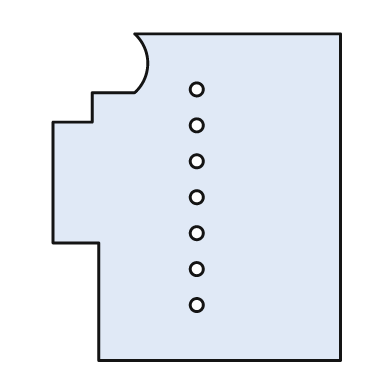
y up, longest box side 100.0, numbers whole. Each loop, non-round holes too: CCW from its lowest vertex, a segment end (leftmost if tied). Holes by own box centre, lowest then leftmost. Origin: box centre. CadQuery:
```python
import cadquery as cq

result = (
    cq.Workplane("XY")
    .moveTo(-30.0, -50.0)
    .lineTo(44.0, -50.0)
    .lineTo(44.0, 50.0)
    .lineTo(-19.0, 50.0)
    .threePointArc((-15.0, 41.0), (-19.0, 32.0))
    .lineTo(-32.0, 32.0)
    .lineTo(-32.0, 23.0)
    .lineTo(-44.0, 23.0)
    .lineTo(-44.0, -14.0)
    .lineTo(-30.0, -14.0)
    .close()
    .moveTo(0.0, -33.0)
    .circle(2.0)
    .moveTo(0.0, -22.0)
    .circle(2.0)
    .moveTo(0.0, -11.0)
    .circle(2.0)
    .moveTo(0.0, 0.0)
    .circle(2.0)
    .moveTo(0.0, 11.0)
    .circle(2.0)
    .moveTo(0.0, 22.0)
    .circle(2.0)
    .moveTo(0.0, 33.0)
    .circle(2.0)
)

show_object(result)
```